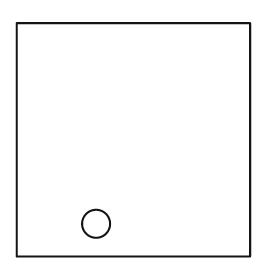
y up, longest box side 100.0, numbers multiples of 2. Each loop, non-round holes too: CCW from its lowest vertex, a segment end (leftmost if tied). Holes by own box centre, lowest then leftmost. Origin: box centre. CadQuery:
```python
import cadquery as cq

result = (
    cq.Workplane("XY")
    .moveTo(-50.0, -50.0)
    .lineTo(50.0, -50.0)
    .lineTo(50.0, 50.0)
    .lineTo(-50.0, 50.0)
    .close()
    .moveTo(-16.0, -36.0)
    .circle(6.0)
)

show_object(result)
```